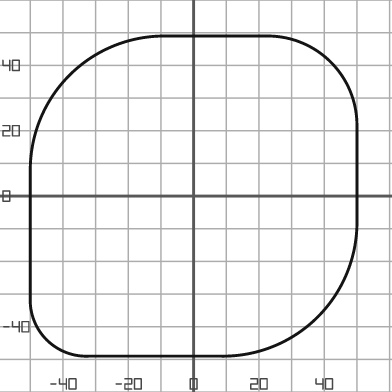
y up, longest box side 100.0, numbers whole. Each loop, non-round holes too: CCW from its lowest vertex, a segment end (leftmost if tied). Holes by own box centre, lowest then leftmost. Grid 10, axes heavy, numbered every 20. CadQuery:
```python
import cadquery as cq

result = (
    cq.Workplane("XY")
    .moveTo(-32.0, -49.0)
    .lineTo(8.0, -49.0)
    .threePointArc((38.0, -37.0), (50.0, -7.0))
    .lineTo(50.0, 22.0)
    .threePointArc((42.0, 41.0), (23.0, 49.0))
    .lineTo(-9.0, 49.0)
    .threePointArc((-38.0, 37.0), (-50.0, 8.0))
    .lineTo(-50.0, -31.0)
    .threePointArc((-45.0, -44.0), (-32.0, -49.0))
    .close()
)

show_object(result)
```